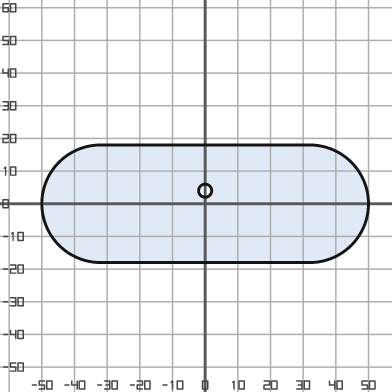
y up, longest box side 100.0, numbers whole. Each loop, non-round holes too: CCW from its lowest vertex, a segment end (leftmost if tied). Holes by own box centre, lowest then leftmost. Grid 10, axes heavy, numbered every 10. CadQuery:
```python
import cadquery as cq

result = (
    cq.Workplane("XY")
    .moveTo(-32.0, -18.0)
    .lineTo(32.0, -18.0)
    .threePointArc((50.0, 0.0), (32.0, 18.0))
    .lineTo(-32.0, 18.0)
    .threePointArc((-50.0, 0.0), (-32.0, -18.0))
    .close()
    .moveTo(0.0, 4.0)
    .circle(2.0)
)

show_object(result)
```